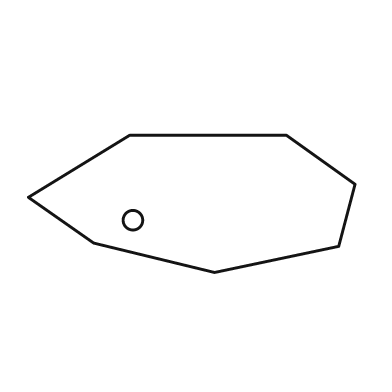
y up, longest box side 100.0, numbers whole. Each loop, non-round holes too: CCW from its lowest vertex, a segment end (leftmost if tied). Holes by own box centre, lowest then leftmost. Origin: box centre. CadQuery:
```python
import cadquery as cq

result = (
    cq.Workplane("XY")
    .moveTo(7.0, -21.0)
    .lineTo(45.0, -13.0)
    .lineTo(50.0, 6.0)
    .lineTo(29.0, 21.0)
    .lineTo(-19.0, 21.0)
    .lineTo(-50.0, 2.0)
    .lineTo(-30.0, -12.0)
    .close()
    .moveTo(-18.0, -5.0)
    .circle(3.0)
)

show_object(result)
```